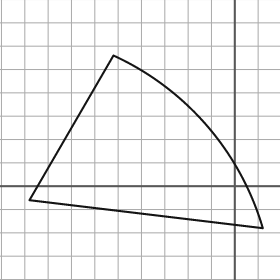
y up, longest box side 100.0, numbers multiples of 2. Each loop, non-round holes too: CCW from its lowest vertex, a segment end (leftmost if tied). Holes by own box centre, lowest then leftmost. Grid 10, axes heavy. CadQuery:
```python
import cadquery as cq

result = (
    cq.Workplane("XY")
    .moveTo(12.0, -18.0)
    .threePointArc((-12.0, 26.0), (-52.0, 56.0))
    .lineTo(-88.0, -6.0)
    .close()
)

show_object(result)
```